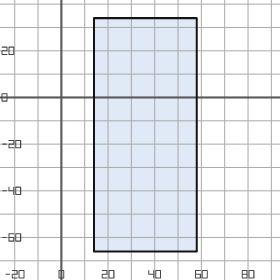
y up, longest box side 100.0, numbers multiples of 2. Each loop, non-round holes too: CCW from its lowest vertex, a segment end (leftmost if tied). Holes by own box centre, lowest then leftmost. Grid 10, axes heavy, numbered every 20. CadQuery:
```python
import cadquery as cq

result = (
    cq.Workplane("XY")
    .moveTo(14.0, -66.0)
    .lineTo(58.0, -66.0)
    .lineTo(58.0, 34.0)
    .lineTo(14.0, 34.0)
    .close()
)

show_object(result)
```